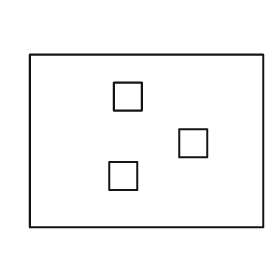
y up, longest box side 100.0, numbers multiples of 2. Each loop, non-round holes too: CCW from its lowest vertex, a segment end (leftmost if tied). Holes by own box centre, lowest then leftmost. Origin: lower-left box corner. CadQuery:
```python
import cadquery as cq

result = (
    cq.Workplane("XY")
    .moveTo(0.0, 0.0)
    .lineTo(100.0, 0.0)
    .lineTo(100.0, 74.0)
    .lineTo(0.0, 74.0)
    .close()
    .moveTo(34.0, 16.0)
    .lineTo(46.0, 16.0)
    .lineTo(46.0, 28.0)
    .lineTo(34.0, 28.0)
    .close()
    .moveTo(64.0, 30.0)
    .lineTo(76.0, 30.0)
    .lineTo(76.0, 42.0)
    .lineTo(64.0, 42.0)
    .close()
    .moveTo(36.0, 50.0)
    .lineTo(48.0, 50.0)
    .lineTo(48.0, 62.0)
    .lineTo(36.0, 62.0)
    .close()
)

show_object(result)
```